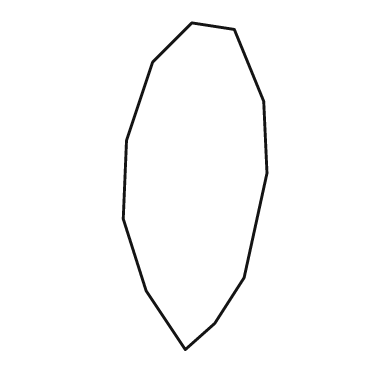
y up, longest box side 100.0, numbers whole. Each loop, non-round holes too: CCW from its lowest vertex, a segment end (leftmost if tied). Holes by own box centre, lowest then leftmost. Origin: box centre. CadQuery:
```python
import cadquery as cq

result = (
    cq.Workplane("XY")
    .moveTo(-3.0, -50.0)
    .lineTo(6.0, -42.0)
    .lineTo(15.0, -28.0)
    .lineTo(22.0, 4.0)
    .lineTo(21.0, 26.0)
    .lineTo(12.0, 48.0)
    .lineTo(-1.0, 50.0)
    .lineTo(-13.0, 38.0)
    .lineTo(-21.0, 14.0)
    .lineTo(-22.0, -10.0)
    .lineTo(-15.0, -32.0)
    .close()
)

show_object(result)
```